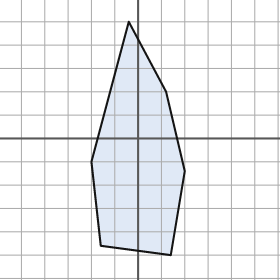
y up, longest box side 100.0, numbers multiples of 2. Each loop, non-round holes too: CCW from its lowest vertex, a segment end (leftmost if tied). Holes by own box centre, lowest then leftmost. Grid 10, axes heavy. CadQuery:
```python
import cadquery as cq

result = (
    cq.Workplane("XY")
    .moveTo(14.0, -50.0)
    .lineTo(20.0, -14.0)
    .lineTo(12.0, 20.0)
    .lineTo(-4.0, 50.0)
    .lineTo(-20.0, -10.0)
    .lineTo(-16.0, -46.0)
    .close()
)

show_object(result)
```